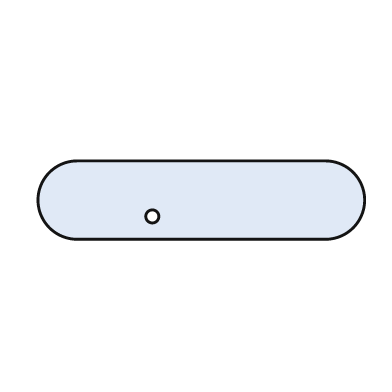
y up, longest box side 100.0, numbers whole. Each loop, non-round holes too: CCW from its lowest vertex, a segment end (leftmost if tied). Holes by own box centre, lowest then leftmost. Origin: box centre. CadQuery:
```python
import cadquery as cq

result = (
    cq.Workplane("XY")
    .moveTo(-38.0, -12.0)
    .lineTo(38.0, -12.0)
    .threePointArc((50.0, 0.0), (38.0, 12.0))
    .lineTo(-38.0, 12.0)
    .threePointArc((-50.0, 0.0), (-38.0, -12.0))
    .close()
    .moveTo(-15.0, -5.0)
    .circle(2.0)
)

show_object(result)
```